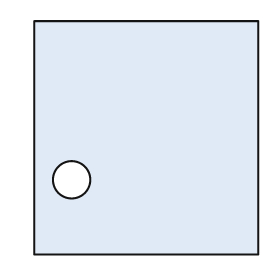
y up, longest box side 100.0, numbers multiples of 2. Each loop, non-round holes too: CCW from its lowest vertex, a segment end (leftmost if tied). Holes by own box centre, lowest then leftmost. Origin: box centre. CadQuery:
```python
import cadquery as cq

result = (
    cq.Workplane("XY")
    .moveTo(-48.0, -50.0)
    .lineTo(48.0, -50.0)
    .lineTo(48.0, 50.0)
    .lineTo(-48.0, 50.0)
    .close()
    .moveTo(-32.0, -18.0)
    .circle(8.0)
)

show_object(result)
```